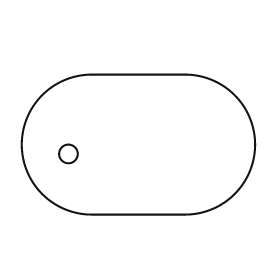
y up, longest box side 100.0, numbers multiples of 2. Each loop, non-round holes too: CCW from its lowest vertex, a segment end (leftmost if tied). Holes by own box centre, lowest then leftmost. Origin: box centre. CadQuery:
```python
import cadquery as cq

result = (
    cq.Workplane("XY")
    .moveTo(-20.0, -30.0)
    .lineTo(20.0, -30.0)
    .threePointArc((50.0, 0.0), (20.0, 30.0))
    .lineTo(-20.0, 30.0)
    .threePointArc((-50.0, 0.0), (-20.0, -30.0))
    .close()
    .moveTo(-30.0, -4.0)
    .circle(4.0)
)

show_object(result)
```